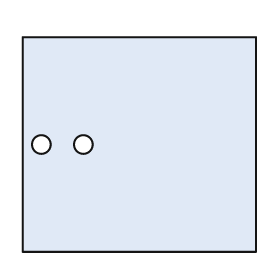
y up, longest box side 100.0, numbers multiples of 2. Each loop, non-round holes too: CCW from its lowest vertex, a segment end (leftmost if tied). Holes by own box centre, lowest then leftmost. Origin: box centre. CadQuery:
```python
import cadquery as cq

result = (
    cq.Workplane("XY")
    .moveTo(-50.0, -46.0)
    .lineTo(50.0, -46.0)
    .lineTo(50.0, 46.0)
    .lineTo(-50.0, 46.0)
    .close()
    .moveTo(-42.0, 0.0)
    .circle(4.0)
    .moveTo(-24.0, 0.0)
    .circle(4.0)
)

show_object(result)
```